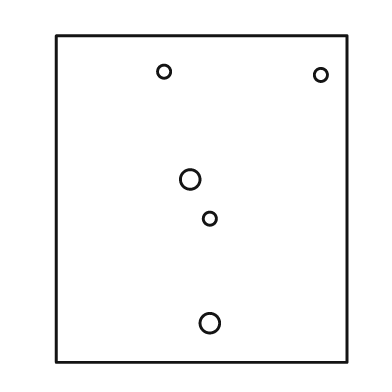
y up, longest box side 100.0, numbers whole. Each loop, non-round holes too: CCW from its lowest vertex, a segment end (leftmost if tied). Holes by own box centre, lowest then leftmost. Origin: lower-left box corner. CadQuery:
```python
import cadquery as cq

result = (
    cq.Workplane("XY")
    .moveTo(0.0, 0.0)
    .lineTo(89.0, 0.0)
    .lineTo(89.0, 100.0)
    .lineTo(0.0, 100.0)
    .close()
    .moveTo(47.0, 12.0)
    .circle(3.0)
    .moveTo(47.0, 44.0)
    .circle(2.0)
    .moveTo(41.0, 56.0)
    .circle(3.0)
    .moveTo(81.0, 88.0)
    .circle(2.0)
    .moveTo(33.0, 89.0)
    .circle(2.0)
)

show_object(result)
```